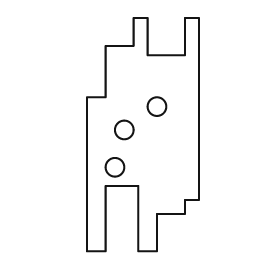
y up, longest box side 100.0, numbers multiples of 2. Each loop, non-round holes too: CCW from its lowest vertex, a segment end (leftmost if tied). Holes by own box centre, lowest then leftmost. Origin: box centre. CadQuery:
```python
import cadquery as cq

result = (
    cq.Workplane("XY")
    .moveTo(-24.0, -50.0)
    .lineTo(-16.0, -50.0)
    .lineTo(-16.0, -22.0)
    .lineTo(-2.0, -22.0)
    .lineTo(-2.0, -50.0)
    .lineTo(6.0, -50.0)
    .lineTo(6.0, -34.0)
    .lineTo(18.0, -34.0)
    .lineTo(18.0, -28.0)
    .lineTo(24.0, -28.0)
    .lineTo(24.0, 50.0)
    .lineTo(18.0, 50.0)
    .lineTo(18.0, 34.0)
    .lineTo(2.0, 34.0)
    .lineTo(2.0, 50.0)
    .lineTo(-4.0, 50.0)
    .lineTo(-4.0, 38.0)
    .lineTo(-16.0, 38.0)
    .lineTo(-16.0, 16.0)
    .lineTo(-24.0, 16.0)
    .close()
    .moveTo(-12.0, -14.0)
    .circle(4.0)
    .moveTo(-8.0, 2.0)
    .circle(4.0)
    .moveTo(6.0, 12.0)
    .circle(4.0)
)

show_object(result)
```